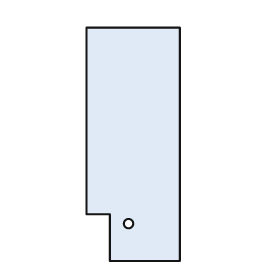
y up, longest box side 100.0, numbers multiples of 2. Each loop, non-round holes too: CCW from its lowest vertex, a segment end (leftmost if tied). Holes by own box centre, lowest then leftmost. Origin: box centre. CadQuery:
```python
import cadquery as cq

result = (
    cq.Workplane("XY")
    .moveTo(-10.0, -50.0)
    .lineTo(20.0, -50.0)
    .lineTo(20.0, 50.0)
    .lineTo(-20.0, 50.0)
    .lineTo(-20.0, -30.0)
    .lineTo(-10.0, -30.0)
    .close()
    .moveTo(-2.0, -34.0)
    .circle(2.0)
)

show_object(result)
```